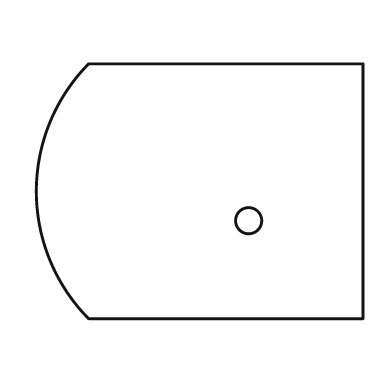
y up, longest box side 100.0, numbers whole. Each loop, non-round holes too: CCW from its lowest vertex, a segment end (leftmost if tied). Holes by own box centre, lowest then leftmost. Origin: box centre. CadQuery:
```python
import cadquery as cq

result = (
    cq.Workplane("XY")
    .moveTo(-34.0, -39.0)
    .lineTo(50.0, -39.0)
    .lineTo(50.0, 39.0)
    .lineTo(-34.0, 39.0)
    .threePointArc((-50.0, 0.0), (-34.0, -39.0))
    .close()
    .moveTo(15.0, -9.0)
    .circle(4.0)
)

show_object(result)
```